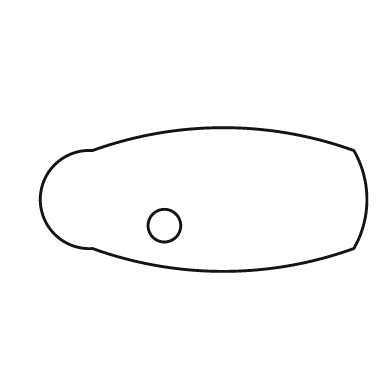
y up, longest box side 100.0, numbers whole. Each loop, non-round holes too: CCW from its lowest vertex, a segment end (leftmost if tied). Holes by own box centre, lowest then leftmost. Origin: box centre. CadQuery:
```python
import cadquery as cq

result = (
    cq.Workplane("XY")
    .moveTo(-34.0, -15.0)
    .threePointArc((6.0, -22.0), (46.0, -15.0))
    .threePointArc((50.0, 0.0), (46.0, 15.0))
    .threePointArc((6.0, 22.0), (-34.0, 15.0))
    .threePointArc((-50.0, 0.0), (-34.0, -15.0))
    .close()
    .moveTo(-12.0, -8.0)
    .circle(5.0)
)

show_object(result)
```